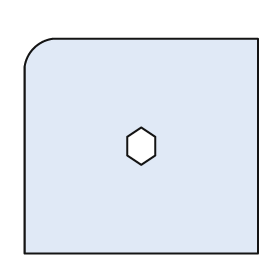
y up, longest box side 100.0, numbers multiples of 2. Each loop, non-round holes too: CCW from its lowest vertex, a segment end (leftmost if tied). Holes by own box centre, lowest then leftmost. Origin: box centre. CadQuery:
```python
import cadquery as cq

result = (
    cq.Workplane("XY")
    .moveTo(-50.0, -46.0)
    .lineTo(50.0, -46.0)
    .lineTo(50.0, 46.0)
    .lineTo(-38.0, 46.0)
    .threePointArc((-46.0, 42.0), (-50.0, 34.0))
    .close()
    .moveTo(0.0, -8.0)
    .lineTo(6.0, -4.0)
    .lineTo(6.0, 4.0)
    .lineTo(0.0, 8.0)
    .lineTo(-6.0, 4.0)
    .lineTo(-6.0, -4.0)
    .close()
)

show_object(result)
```